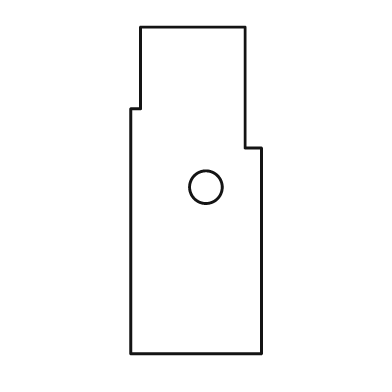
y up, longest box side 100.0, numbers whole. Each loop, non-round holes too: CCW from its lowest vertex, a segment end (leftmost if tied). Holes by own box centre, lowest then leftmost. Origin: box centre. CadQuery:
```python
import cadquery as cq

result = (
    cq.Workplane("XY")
    .moveTo(-20.0, -50.0)
    .lineTo(20.0, -50.0)
    .lineTo(20.0, 13.0)
    .lineTo(15.0, 13.0)
    .lineTo(15.0, 50.0)
    .lineTo(-17.0, 50.0)
    .lineTo(-17.0, 25.0)
    .lineTo(-20.0, 25.0)
    .close()
    .moveTo(3.0, 1.0)
    .circle(5.0)
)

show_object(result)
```